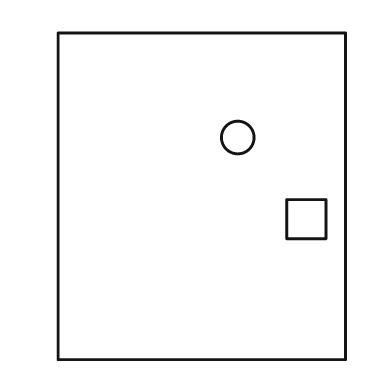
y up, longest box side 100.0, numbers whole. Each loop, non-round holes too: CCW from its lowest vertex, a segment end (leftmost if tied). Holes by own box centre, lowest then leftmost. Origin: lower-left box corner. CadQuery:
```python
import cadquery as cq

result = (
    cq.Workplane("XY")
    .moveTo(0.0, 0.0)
    .lineTo(88.0, 0.0)
    .lineTo(88.0, 100.0)
    .lineTo(0.0, 100.0)
    .close()
    .moveTo(70.0, 37.0)
    .lineTo(82.0, 37.0)
    .lineTo(82.0, 49.0)
    .lineTo(70.0, 49.0)
    .close()
    .moveTo(55.0, 68.0)
    .circle(5.0)
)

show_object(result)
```